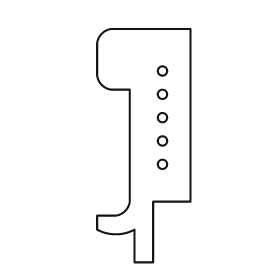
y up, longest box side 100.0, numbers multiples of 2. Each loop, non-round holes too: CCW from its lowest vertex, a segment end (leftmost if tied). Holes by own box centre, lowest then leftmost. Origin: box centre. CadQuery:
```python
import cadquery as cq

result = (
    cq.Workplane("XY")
    .moveTo(-4.0, -50.0)
    .lineTo(4.0, -50.0)
    .lineTo(4.0, -24.0)
    .lineTo(20.0, -24.0)
    .lineTo(20.0, 50.0)
    .lineTo(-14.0, 50.0)
    .threePointArc((-18.0, 48.0), (-20.0, 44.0))
    .lineTo(-20.0, 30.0)
    .threePointArc((-18.0, 26.0), (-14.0, 24.0))
    .lineTo(-6.0, 24.0)
    .lineTo(-6.0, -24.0)
    .threePointArc((-8.0, -28.0), (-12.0, -30.0))
    .lineTo(-20.0, -30.0)
    .lineTo(-20.0, -36.0)
    .threePointArc((-12.0, -38.0), (-4.0, -36.0))
    .close()
    .moveTo(8.0, -8.0)
    .circle(2.0)
    .moveTo(8.0, 2.0)
    .circle(2.0)
    .moveTo(8.0, 12.0)
    .circle(2.0)
    .moveTo(8.0, 22.0)
    .circle(2.0)
    .moveTo(8.0, 32.0)
    .circle(2.0)
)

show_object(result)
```